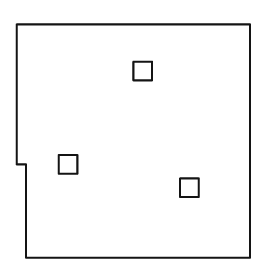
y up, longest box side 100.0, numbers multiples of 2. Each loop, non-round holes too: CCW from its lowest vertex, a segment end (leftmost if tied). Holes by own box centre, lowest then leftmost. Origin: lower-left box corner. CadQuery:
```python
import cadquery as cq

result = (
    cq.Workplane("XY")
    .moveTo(4.0, 0.0)
    .lineTo(100.0, 0.0)
    .lineTo(100.0, 100.0)
    .lineTo(0.0, 100.0)
    .lineTo(0.0, 40.0)
    .lineTo(4.0, 40.0)
    .close()
    .moveTo(70.0, 26.0)
    .lineTo(78.0, 26.0)
    .lineTo(78.0, 34.0)
    .lineTo(70.0, 34.0)
    .close()
    .moveTo(18.0, 36.0)
    .lineTo(26.0, 36.0)
    .lineTo(26.0, 44.0)
    .lineTo(18.0, 44.0)
    .close()
    .moveTo(50.0, 76.0)
    .lineTo(58.0, 76.0)
    .lineTo(58.0, 84.0)
    .lineTo(50.0, 84.0)
    .close()
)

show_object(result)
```